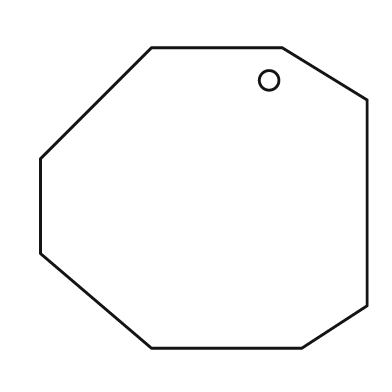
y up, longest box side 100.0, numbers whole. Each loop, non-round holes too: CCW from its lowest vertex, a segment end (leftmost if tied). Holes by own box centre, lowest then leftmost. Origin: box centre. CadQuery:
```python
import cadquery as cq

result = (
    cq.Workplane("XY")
    .moveTo(-16.0, -46.0)
    .lineTo(30.0, -46.0)
    .lineTo(50.0, -33.0)
    .lineTo(50.0, 30.0)
    .lineTo(24.0, 46.0)
    .lineTo(-16.0, 46.0)
    .lineTo(-50.0, 12.0)
    .lineTo(-50.0, -17.0)
    .close()
    .moveTo(20.0, 36.0)
    .circle(3.0)
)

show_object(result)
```